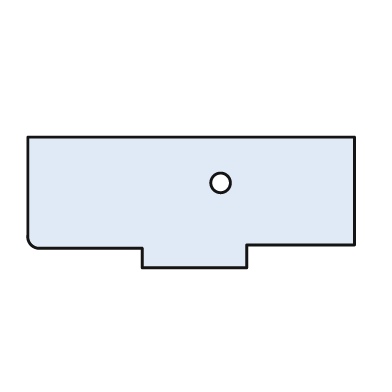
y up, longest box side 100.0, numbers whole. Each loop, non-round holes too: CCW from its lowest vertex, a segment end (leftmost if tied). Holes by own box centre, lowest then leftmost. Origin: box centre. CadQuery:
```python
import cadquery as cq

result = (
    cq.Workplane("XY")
    .moveTo(-15.0, -20.0)
    .lineTo(17.0, -20.0)
    .lineTo(17.0, -13.0)
    .lineTo(50.0, -13.0)
    .lineTo(50.0, 20.0)
    .lineTo(-50.0, 20.0)
    .lineTo(-50.0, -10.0)
    .threePointArc((-49.0, -13.0), (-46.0, -14.0))
    .lineTo(-15.0, -14.0)
    .close()
    .moveTo(9.0, 6.0)
    .circle(3.0)
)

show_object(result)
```